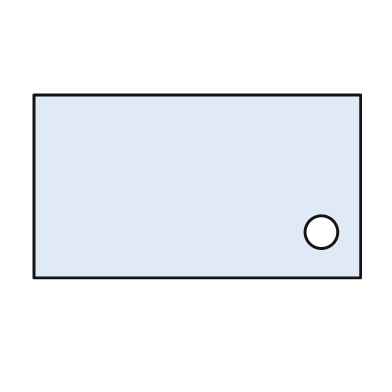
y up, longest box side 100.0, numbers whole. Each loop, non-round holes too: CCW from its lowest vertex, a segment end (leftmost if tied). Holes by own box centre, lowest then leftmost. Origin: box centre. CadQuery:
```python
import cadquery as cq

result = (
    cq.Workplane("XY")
    .moveTo(-50.0, -28.0)
    .lineTo(50.0, -28.0)
    .lineTo(50.0, 28.0)
    .lineTo(-50.0, 28.0)
    .close()
    .moveTo(38.0, -14.0)
    .circle(5.0)
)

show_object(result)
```